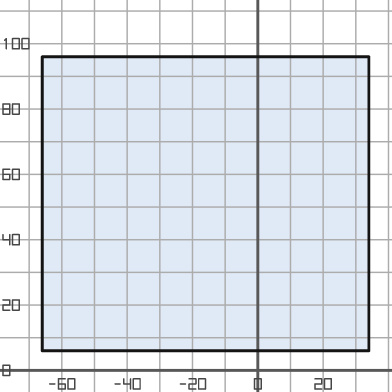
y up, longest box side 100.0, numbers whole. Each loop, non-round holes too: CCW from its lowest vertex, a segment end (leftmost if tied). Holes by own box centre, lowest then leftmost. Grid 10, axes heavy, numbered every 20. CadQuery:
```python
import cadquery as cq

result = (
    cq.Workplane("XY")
    .moveTo(-66.0, 6.0)
    .lineTo(34.0, 6.0)
    .lineTo(34.0, 96.0)
    .lineTo(-66.0, 96.0)
    .close()
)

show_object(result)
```